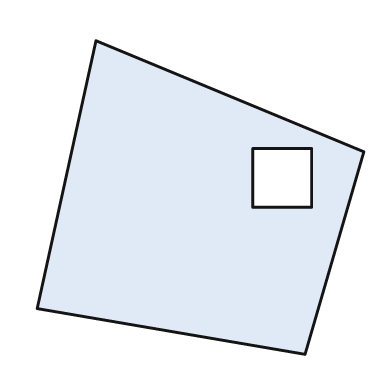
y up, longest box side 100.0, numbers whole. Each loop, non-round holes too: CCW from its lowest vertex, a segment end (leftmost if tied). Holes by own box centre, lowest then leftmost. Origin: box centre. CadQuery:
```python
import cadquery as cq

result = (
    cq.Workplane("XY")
    .moveTo(32.0, -48.0)
    .lineTo(50.0, 14.0)
    .lineTo(-32.0, 48.0)
    .lineTo(-50.0, -34.0)
    .close()
    .moveTo(16.0, -3.0)
    .lineTo(34.0, -3.0)
    .lineTo(34.0, 15.0)
    .lineTo(16.0, 15.0)
    .close()
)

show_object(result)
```